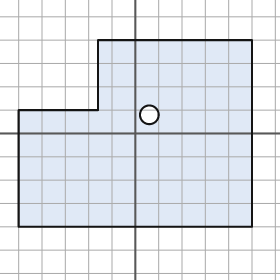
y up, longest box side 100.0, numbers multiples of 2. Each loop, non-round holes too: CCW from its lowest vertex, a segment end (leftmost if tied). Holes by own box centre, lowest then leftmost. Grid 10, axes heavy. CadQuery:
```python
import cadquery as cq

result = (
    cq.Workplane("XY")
    .moveTo(-50.0, -40.0)
    .lineTo(50.0, -40.0)
    .lineTo(50.0, 40.0)
    .lineTo(-16.0, 40.0)
    .lineTo(-16.0, 10.0)
    .lineTo(-50.0, 10.0)
    .close()
    .moveTo(6.0, 8.0)
    .circle(4.0)
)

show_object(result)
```